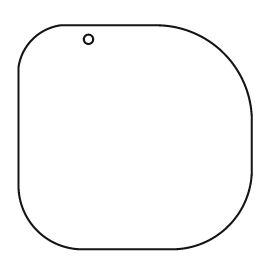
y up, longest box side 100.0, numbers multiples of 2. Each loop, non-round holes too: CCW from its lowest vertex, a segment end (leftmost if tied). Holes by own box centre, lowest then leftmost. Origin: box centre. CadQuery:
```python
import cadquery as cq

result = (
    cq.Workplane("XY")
    .moveTo(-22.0, -48.0)
    .lineTo(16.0, -48.0)
    .threePointArc((40.0, -38.0), (50.0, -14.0))
    .lineTo(50.0, 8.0)
    .threePointArc((38.0, 36.0), (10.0, 48.0))
    .lineTo(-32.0, 48.0)
    .threePointArc((-44.0, 42.0), (-50.0, 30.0))
    .lineTo(-50.0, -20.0)
    .threePointArc((-42.0, -40.0), (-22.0, -48.0))
    .close()
    .moveTo(-20.0, 42.0)
    .circle(2.0)
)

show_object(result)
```